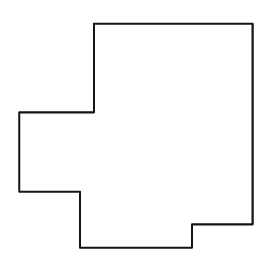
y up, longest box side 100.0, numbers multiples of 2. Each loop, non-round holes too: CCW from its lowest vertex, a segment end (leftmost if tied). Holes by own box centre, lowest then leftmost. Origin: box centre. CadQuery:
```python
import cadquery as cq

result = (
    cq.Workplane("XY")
    .moveTo(-24.0, -48.0)
    .lineTo(24.0, -48.0)
    .lineTo(24.0, -38.0)
    .lineTo(50.0, -38.0)
    .lineTo(50.0, 48.0)
    .lineTo(-18.0, 48.0)
    .lineTo(-18.0, 10.0)
    .lineTo(-50.0, 10.0)
    .lineTo(-50.0, -24.0)
    .lineTo(-24.0, -24.0)
    .close()
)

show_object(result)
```